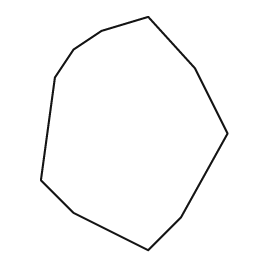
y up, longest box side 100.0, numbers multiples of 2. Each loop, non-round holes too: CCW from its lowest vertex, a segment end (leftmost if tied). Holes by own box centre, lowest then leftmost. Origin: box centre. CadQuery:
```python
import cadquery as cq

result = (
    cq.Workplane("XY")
    .moveTo(6.0, -50.0)
    .lineTo(20.0, -36.0)
    .lineTo(40.0, 0.0)
    .lineTo(26.0, 28.0)
    .lineTo(6.0, 50.0)
    .lineTo(-14.0, 44.0)
    .lineTo(-26.0, 36.0)
    .lineTo(-34.0, 24.0)
    .lineTo(-40.0, -20.0)
    .lineTo(-26.0, -34.0)
    .close()
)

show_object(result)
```